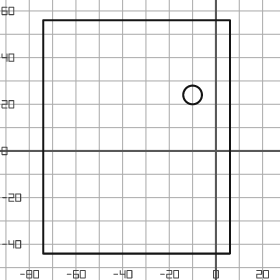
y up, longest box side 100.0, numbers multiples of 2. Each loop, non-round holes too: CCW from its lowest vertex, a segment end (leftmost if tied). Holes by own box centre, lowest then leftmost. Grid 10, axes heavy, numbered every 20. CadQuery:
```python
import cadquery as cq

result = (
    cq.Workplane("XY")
    .moveTo(-74.0, -44.0)
    .lineTo(6.0, -44.0)
    .lineTo(6.0, 56.0)
    .lineTo(-74.0, 56.0)
    .close()
    .moveTo(-10.0, 24.0)
    .circle(4.0)
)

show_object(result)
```